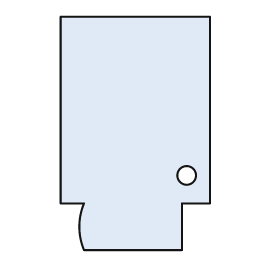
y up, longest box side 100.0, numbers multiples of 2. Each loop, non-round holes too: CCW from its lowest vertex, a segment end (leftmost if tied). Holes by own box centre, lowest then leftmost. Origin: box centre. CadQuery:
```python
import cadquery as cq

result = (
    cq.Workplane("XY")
    .moveTo(-22.0, -50.0)
    .lineTo(20.0, -50.0)
    .lineTo(20.0, -30.0)
    .lineTo(32.0, -30.0)
    .lineTo(32.0, 50.0)
    .lineTo(-32.0, 50.0)
    .lineTo(-32.0, -30.0)
    .lineTo(-22.0, -30.0)
    .threePointArc((-24.0, -40.0), (-22.0, -50.0))
    .close()
    .moveTo(22.0, -18.0)
    .circle(4.0)
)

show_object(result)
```